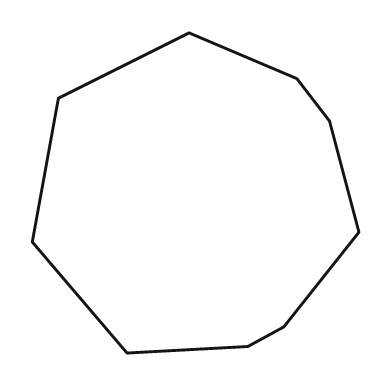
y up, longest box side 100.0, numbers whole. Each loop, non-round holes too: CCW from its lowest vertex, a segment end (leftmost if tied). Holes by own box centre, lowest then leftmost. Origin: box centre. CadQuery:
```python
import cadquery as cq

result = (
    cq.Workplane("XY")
    .moveTo(-21.0, -49.0)
    .lineTo(16.0, -47.0)
    .lineTo(27.0, -41.0)
    .lineTo(50.0, -12.0)
    .lineTo(41.0, 22.0)
    .lineTo(31.0, 35.0)
    .lineTo(-2.0, 49.0)
    .lineTo(-42.0, 29.0)
    .lineTo(-50.0, -15.0)
    .close()
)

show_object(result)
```